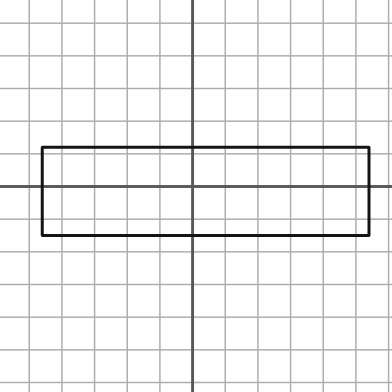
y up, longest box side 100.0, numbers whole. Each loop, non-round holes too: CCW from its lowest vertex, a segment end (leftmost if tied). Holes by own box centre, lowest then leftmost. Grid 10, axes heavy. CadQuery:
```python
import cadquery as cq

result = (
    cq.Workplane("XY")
    .moveTo(-46.0, -15.0)
    .lineTo(54.0, -15.0)
    .lineTo(54.0, 12.0)
    .lineTo(-46.0, 12.0)
    .close()
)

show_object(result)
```